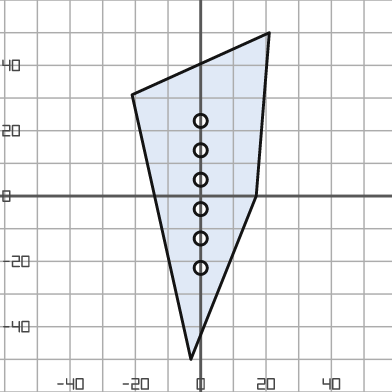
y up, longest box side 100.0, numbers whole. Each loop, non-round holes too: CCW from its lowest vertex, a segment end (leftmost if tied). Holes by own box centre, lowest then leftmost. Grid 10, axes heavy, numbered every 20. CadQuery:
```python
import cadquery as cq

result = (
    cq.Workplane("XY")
    .moveTo(-3.0, -50.0)
    .lineTo(17.0, 0.0)
    .lineTo(21.0, 50.0)
    .lineTo(-21.0, 31.0)
    .close()
    .moveTo(0.0, -22.0)
    .circle(2.0)
    .moveTo(0.0, -13.0)
    .circle(2.0)
    .moveTo(0.0, -4.0)
    .circle(2.0)
    .moveTo(0.0, 5.0)
    .circle(2.0)
    .moveTo(0.0, 14.0)
    .circle(2.0)
    .moveTo(0.0, 23.0)
    .circle(2.0)
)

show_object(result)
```